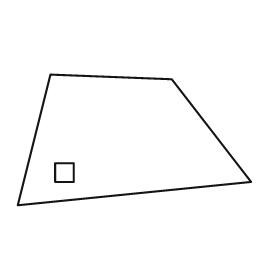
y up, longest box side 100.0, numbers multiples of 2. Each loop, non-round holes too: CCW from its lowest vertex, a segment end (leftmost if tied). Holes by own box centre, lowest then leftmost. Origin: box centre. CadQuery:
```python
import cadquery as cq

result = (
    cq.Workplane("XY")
    .moveTo(-50.0, -28.0)
    .lineTo(50.0, -18.0)
    .lineTo(16.0, 26.0)
    .lineTo(-36.0, 28.0)
    .close()
    .moveTo(-34.0, -18.0)
    .lineTo(-26.0, -18.0)
    .lineTo(-26.0, -10.0)
    .lineTo(-34.0, -10.0)
    .close()
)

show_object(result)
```